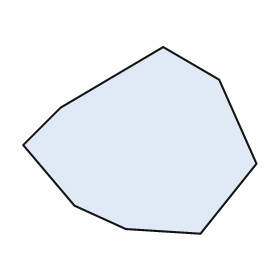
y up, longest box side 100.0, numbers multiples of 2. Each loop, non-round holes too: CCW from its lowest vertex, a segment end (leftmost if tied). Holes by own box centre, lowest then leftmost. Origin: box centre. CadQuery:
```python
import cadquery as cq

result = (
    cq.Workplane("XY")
    .moveTo(26.0, -40.0)
    .lineTo(50.0, -10.0)
    .lineTo(34.0, 26.0)
    .lineTo(10.0, 40.0)
    .lineTo(-34.0, 14.0)
    .lineTo(-50.0, -2.0)
    .lineTo(-28.0, -28.0)
    .lineTo(-6.0, -38.0)
    .close()
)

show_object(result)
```